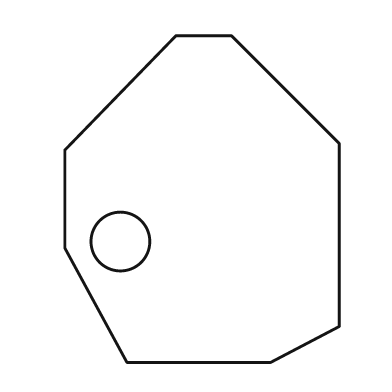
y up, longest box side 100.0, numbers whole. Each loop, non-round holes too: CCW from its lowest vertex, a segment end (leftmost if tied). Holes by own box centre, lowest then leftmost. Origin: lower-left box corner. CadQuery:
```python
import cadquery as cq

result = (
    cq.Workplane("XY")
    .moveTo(19.0, 0.0)
    .lineTo(63.0, 0.0)
    .lineTo(84.0, 11.0)
    .lineTo(84.0, 67.0)
    .lineTo(51.0, 100.0)
    .lineTo(34.0, 100.0)
    .lineTo(0.0, 65.0)
    .lineTo(0.0, 35.0)
    .close()
    .moveTo(17.0, 37.0)
    .circle(9.0)
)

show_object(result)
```